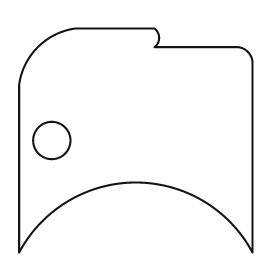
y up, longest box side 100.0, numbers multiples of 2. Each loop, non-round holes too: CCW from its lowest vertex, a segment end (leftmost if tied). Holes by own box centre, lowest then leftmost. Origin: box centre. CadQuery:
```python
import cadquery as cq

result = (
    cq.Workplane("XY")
    .moveTo(-50.0, -48.0)
    .threePointArc((0.0, -18.0), (50.0, -48.0))
    .lineTo(50.0, 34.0)
    .threePointArc((48.0, 38.0), (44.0, 40.0))
    .lineTo(8.0, 40.0)
    .threePointArc((10.0, 44.0), (8.0, 48.0))
    .lineTo(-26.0, 48.0)
    .threePointArc((-42.0, 40.0), (-50.0, 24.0))
    .close()
    .moveTo(-36.0, 0.0)
    .circle(8.0)
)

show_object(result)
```